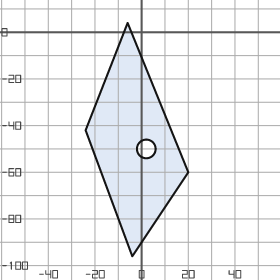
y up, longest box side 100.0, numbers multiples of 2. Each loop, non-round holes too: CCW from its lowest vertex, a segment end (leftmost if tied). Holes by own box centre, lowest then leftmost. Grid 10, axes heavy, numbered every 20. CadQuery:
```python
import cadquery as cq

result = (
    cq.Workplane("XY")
    .moveTo(-4.0, -96.0)
    .lineTo(20.0, -60.0)
    .lineTo(-6.0, 4.0)
    .lineTo(-24.0, -42.0)
    .close()
    .moveTo(2.0, -50.0)
    .circle(4.0)
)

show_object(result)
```